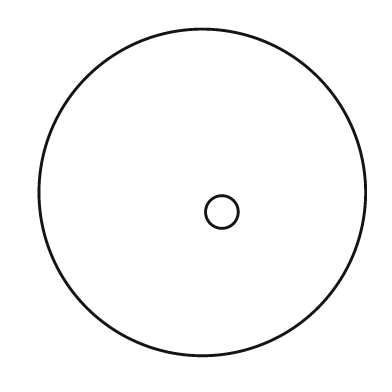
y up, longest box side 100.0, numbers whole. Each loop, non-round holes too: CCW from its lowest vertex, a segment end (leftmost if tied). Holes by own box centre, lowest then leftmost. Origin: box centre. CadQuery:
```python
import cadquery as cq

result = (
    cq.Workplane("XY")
    .moveTo(0.0, 0.0)
    .circle(50.0)
    .moveTo(6.0, -6.0)
    .circle(5.0)
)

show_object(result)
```